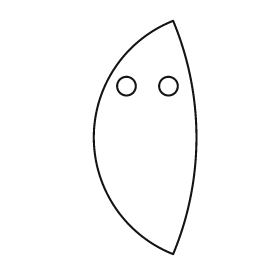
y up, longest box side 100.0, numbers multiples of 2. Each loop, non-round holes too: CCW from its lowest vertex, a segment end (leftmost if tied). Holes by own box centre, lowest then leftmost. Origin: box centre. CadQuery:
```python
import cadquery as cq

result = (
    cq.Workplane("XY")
    .moveTo(12.0, -50.0)
    .threePointArc((22.0, 0.0), (12.0, 50.0))
    .threePointArc((-22.0, 0.0), (12.0, -50.0))
    .close()
    .moveTo(-8.0, 22.0)
    .circle(4.0)
    .moveTo(10.0, 22.0)
    .circle(4.0)
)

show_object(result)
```